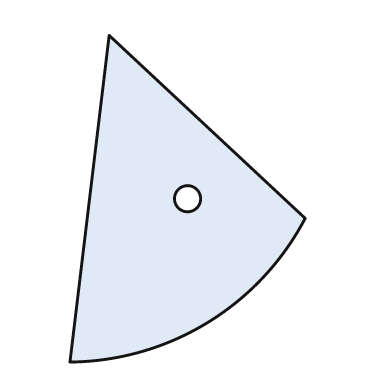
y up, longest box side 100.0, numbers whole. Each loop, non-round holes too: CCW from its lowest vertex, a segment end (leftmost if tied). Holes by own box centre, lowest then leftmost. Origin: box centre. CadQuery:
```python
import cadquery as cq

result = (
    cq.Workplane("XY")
    .moveTo(-36.0, -50.0)
    .threePointArc((6.0, -38.0), (36.0, -6.0))
    .lineTo(-24.0, 50.0)
    .close()
    .moveTo(0.0, 0.0)
    .circle(4.0)
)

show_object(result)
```